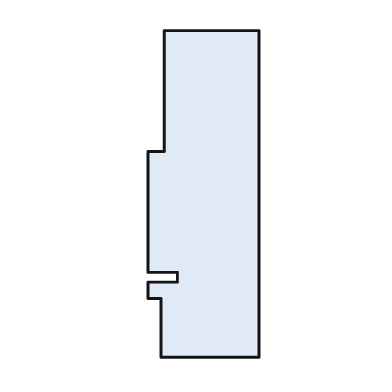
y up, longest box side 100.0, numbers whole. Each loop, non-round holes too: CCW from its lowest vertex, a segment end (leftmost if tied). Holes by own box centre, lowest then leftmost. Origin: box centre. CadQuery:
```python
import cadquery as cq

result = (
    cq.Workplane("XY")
    .moveTo(-13.0, -50.0)
    .lineTo(17.0, -50.0)
    .lineTo(17.0, 50.0)
    .lineTo(-12.0, 50.0)
    .lineTo(-12.0, 13.0)
    .lineTo(-17.0, 13.0)
    .lineTo(-17.0, -24.0)
    .lineTo(-8.0, -24.0)
    .lineTo(-8.0, -27.0)
    .lineTo(-17.0, -27.0)
    .lineTo(-17.0, -32.0)
    .lineTo(-13.0, -32.0)
    .close()
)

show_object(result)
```